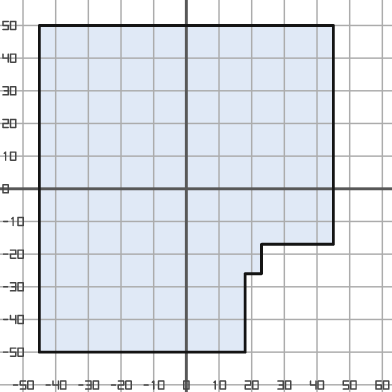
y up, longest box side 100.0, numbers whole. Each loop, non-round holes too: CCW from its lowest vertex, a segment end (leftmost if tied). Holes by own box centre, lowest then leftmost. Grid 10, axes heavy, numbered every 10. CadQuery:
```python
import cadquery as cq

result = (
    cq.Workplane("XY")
    .moveTo(-45.0, -50.0)
    .lineTo(18.0, -50.0)
    .lineTo(18.0, -26.0)
    .lineTo(23.0, -26.0)
    .lineTo(23.0, -17.0)
    .lineTo(45.0, -17.0)
    .lineTo(45.0, 50.0)
    .lineTo(-45.0, 50.0)
    .close()
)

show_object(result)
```